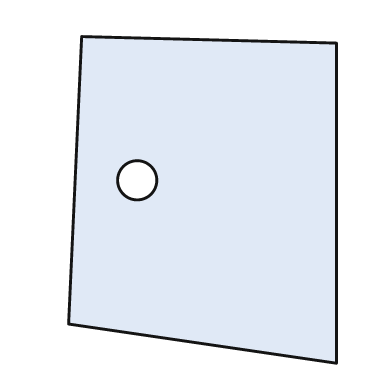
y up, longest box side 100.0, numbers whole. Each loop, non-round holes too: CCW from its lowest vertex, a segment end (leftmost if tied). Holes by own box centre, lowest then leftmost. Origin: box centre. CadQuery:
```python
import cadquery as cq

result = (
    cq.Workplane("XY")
    .moveTo(41.0, -50.0)
    .lineTo(41.0, 48.0)
    .lineTo(-37.0, 50.0)
    .lineTo(-41.0, -38.0)
    .close()
    .moveTo(-20.0, 6.0)
    .circle(6.0)
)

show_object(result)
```